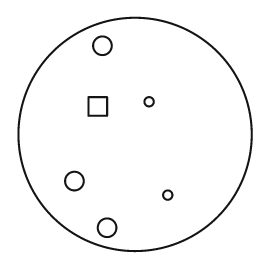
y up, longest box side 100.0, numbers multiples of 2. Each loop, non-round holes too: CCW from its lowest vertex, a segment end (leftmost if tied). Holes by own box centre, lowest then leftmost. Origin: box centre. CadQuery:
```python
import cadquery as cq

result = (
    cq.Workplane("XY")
    .moveTo(0.0, 0.0)
    .circle(50.0)
    .moveTo(-12.0, -40.0)
    .circle(4.0)
    .moveTo(14.0, -26.0)
    .circle(2.0)
    .moveTo(-26.0, -20.0)
    .circle(4.0)
    .moveTo(-20.0, 8.0)
    .lineTo(-12.0, 8.0)
    .lineTo(-12.0, 16.0)
    .lineTo(-20.0, 16.0)
    .close()
    .moveTo(6.0, 14.0)
    .circle(2.0)
    .moveTo(-14.0, 38.0)
    .circle(4.0)
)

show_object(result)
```